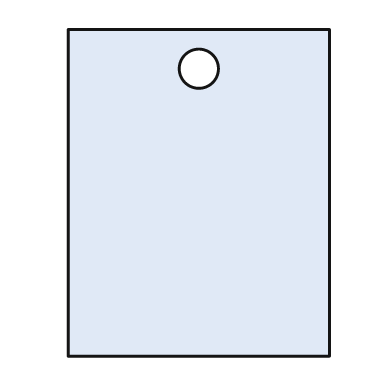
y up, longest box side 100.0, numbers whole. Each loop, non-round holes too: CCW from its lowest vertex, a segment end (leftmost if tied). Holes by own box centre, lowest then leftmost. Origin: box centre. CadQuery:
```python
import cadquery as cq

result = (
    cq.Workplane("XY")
    .moveTo(-40.0, -50.0)
    .lineTo(40.0, -50.0)
    .lineTo(40.0, 50.0)
    .lineTo(-40.0, 50.0)
    .close()
    .moveTo(0.0, 38.0)
    .circle(6.0)
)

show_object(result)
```